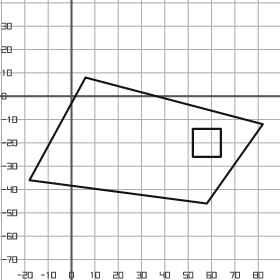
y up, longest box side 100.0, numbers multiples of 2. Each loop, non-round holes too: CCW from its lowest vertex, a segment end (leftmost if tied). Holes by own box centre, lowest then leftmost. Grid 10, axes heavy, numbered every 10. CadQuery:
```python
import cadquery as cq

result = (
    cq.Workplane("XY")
    .moveTo(58.0, -46.0)
    .lineTo(82.0, -12.0)
    .lineTo(6.0, 8.0)
    .lineTo(-18.0, -36.0)
    .close()
    .moveTo(52.0, -26.0)
    .lineTo(64.0, -26.0)
    .lineTo(64.0, -14.0)
    .lineTo(52.0, -14.0)
    .close()
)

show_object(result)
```